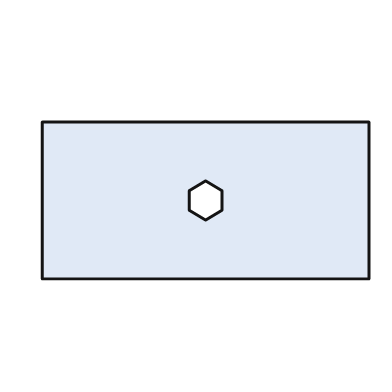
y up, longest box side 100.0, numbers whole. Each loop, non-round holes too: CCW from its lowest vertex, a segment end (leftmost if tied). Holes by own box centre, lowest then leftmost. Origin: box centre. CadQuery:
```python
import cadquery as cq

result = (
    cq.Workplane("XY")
    .moveTo(-50.0, -24.0)
    .lineTo(50.0, -24.0)
    .lineTo(50.0, 24.0)
    .lineTo(-50.0, 24.0)
    .close()
    .moveTo(0.0, -6.0)
    .lineTo(5.0, -3.0)
    .lineTo(5.0, 3.0)
    .lineTo(0.0, 6.0)
    .lineTo(-5.0, 3.0)
    .lineTo(-5.0, -3.0)
    .close()
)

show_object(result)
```